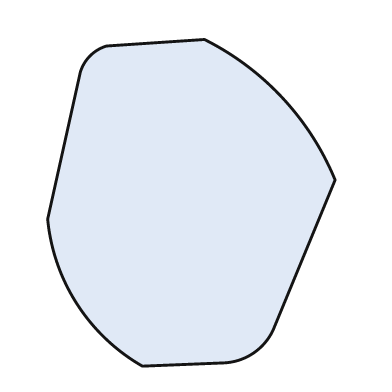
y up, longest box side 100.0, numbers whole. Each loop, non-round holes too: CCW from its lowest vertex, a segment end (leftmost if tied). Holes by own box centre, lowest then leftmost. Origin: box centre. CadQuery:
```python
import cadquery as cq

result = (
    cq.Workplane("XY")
    .moveTo(-15.0, -50.0)
    .lineTo(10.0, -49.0)
    .threePointArc((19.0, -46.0), (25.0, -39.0))
    .lineTo(44.0, 7.0)
    .threePointArc((28.0, 32.0), (4.0, 50.0))
    .lineTo(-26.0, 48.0)
    .threePointArc((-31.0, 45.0), (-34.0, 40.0))
    .lineTo(-44.0, -5.0)
    .threePointArc((-35.0, -31.0), (-15.0, -50.0))
    .close()
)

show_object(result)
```